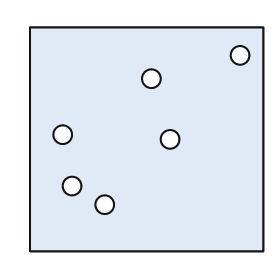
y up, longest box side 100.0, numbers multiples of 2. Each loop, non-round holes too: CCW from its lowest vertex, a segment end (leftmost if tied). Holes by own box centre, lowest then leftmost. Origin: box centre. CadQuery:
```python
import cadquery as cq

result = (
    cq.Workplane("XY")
    .moveTo(-50.0, -48.0)
    .lineTo(50.0, -48.0)
    .lineTo(50.0, 48.0)
    .lineTo(-50.0, 48.0)
    .close()
    .moveTo(-18.0, -28.0)
    .circle(4.0)
    .moveTo(-32.0, -20.0)
    .circle(4.0)
    .moveTo(10.0, 0.0)
    .circle(4.0)
    .moveTo(-36.0, 2.0)
    .circle(4.0)
    .moveTo(2.0, 26.0)
    .circle(4.0)
    .moveTo(40.0, 36.0)
    .circle(4.0)
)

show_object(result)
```